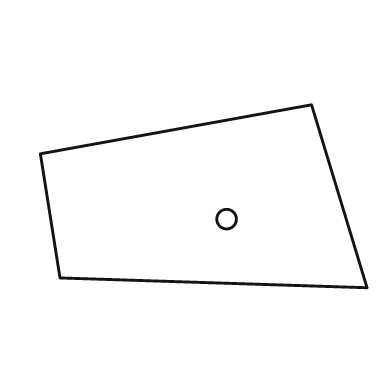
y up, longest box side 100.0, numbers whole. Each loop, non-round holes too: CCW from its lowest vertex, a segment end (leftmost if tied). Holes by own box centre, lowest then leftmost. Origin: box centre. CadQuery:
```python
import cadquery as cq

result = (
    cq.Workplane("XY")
    .moveTo(50.0, -28.0)
    .lineTo(33.0, 28.0)
    .lineTo(-50.0, 13.0)
    .lineTo(-44.0, -25.0)
    .close()
    .moveTo(7.0, -7.0)
    .circle(3.0)
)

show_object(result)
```